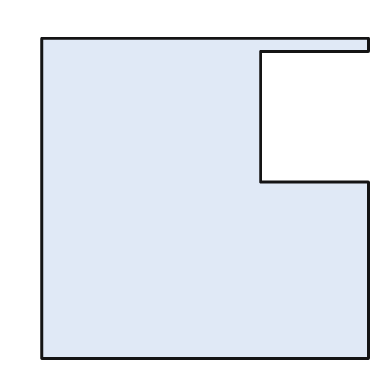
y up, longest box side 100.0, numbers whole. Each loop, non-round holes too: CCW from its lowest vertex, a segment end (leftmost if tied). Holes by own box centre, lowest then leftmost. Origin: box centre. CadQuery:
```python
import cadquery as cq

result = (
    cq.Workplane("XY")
    .moveTo(-50.0, -49.0)
    .lineTo(50.0, -49.0)
    .lineTo(50.0, 5.0)
    .lineTo(17.0, 5.0)
    .lineTo(17.0, 45.0)
    .lineTo(50.0, 45.0)
    .lineTo(50.0, 49.0)
    .lineTo(-50.0, 49.0)
    .close()
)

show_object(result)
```